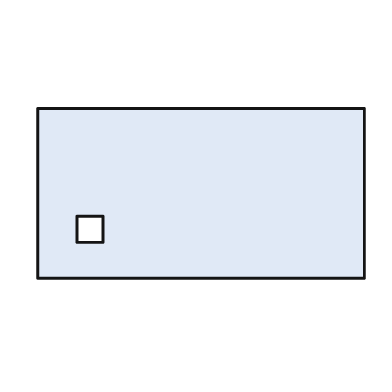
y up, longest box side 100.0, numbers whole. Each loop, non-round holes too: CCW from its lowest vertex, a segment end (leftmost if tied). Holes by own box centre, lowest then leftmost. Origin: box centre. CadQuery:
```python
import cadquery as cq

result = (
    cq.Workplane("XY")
    .moveTo(-50.0, -26.0)
    .lineTo(50.0, -26.0)
    .lineTo(50.0, 26.0)
    .lineTo(-50.0, 26.0)
    .close()
    .moveTo(-38.0, -15.0)
    .lineTo(-30.0, -15.0)
    .lineTo(-30.0, -7.0)
    .lineTo(-38.0, -7.0)
    .close()
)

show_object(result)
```